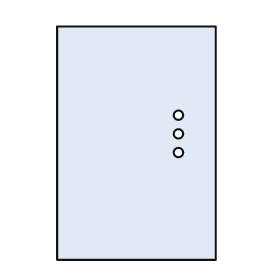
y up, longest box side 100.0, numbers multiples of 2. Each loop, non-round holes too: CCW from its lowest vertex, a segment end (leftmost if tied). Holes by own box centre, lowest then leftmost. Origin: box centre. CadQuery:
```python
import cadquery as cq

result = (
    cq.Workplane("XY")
    .moveTo(-34.0, -50.0)
    .lineTo(34.0, -50.0)
    .lineTo(34.0, 50.0)
    .lineTo(-34.0, 50.0)
    .close()
    .moveTo(18.0, -4.0)
    .circle(2.0)
    .moveTo(18.0, 4.0)
    .circle(2.0)
    .moveTo(18.0, 12.0)
    .circle(2.0)
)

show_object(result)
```